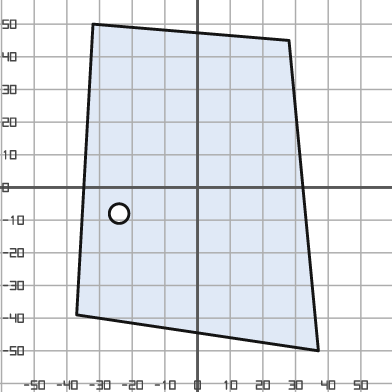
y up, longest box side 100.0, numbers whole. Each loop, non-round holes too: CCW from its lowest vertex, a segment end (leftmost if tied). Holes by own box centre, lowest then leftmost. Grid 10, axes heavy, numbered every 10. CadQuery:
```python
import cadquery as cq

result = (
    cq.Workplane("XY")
    .moveTo(37.0, -50.0)
    .lineTo(28.0, 45.0)
    .lineTo(-32.0, 50.0)
    .lineTo(-37.0, -39.0)
    .close()
    .moveTo(-24.0, -8.0)
    .circle(3.0)
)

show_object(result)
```